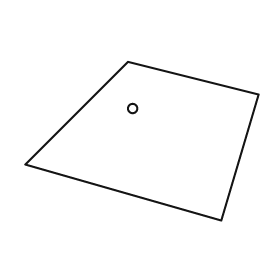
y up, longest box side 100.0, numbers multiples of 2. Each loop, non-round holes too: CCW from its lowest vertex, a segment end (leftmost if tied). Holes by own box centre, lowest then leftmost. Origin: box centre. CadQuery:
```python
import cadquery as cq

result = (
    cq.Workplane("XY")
    .moveTo(34.0, -34.0)
    .lineTo(50.0, 20.0)
    .lineTo(-6.0, 34.0)
    .lineTo(-50.0, -10.0)
    .close()
    .moveTo(-4.0, 14.0)
    .circle(2.0)
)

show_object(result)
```